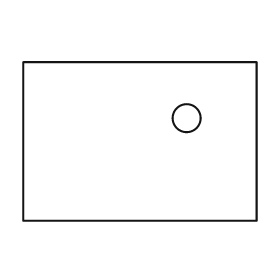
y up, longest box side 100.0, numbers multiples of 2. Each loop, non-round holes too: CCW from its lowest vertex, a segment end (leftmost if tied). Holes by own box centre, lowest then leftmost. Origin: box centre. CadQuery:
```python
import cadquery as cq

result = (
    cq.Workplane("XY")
    .moveTo(-50.0, -34.0)
    .lineTo(50.0, -34.0)
    .lineTo(50.0, 34.0)
    .lineTo(-50.0, 34.0)
    .close()
    .moveTo(20.0, 10.0)
    .circle(6.0)
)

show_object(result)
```